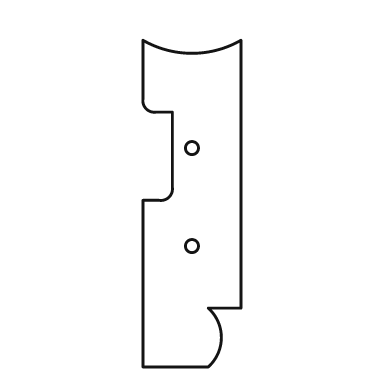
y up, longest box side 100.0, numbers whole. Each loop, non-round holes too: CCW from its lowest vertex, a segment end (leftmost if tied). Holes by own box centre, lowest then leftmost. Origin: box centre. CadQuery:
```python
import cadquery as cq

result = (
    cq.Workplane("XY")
    .moveTo(-15.0, -50.0)
    .lineTo(5.0, -50.0)
    .threePointArc((9.0, -41.0), (5.0, -32.0))
    .lineTo(15.0, -32.0)
    .lineTo(15.0, 50.0)
    .threePointArc((0.0, 46.0), (-15.0, 50.0))
    .lineTo(-15.0, 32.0)
    .threePointArc((-14.0, 29.0), (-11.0, 28.0))
    .lineTo(-6.0, 28.0)
    .lineTo(-6.0, 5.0)
    .threePointArc((-7.0, 2.0), (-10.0, 1.0))
    .lineTo(-15.0, 1.0)
    .close()
    .moveTo(0.0, -13.0)
    .circle(2.0)
    .moveTo(0.0, 17.0)
    .circle(2.0)
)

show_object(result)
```